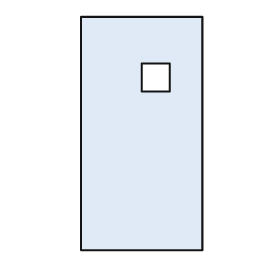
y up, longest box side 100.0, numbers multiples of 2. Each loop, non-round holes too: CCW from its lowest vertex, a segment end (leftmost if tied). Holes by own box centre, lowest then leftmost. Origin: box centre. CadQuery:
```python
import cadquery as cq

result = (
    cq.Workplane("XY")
    .moveTo(-26.0, -50.0)
    .lineTo(26.0, -50.0)
    .lineTo(26.0, 50.0)
    .lineTo(-26.0, 50.0)
    .close()
    .moveTo(0.0, 18.0)
    .lineTo(12.0, 18.0)
    .lineTo(12.0, 30.0)
    .lineTo(0.0, 30.0)
    .close()
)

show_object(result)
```